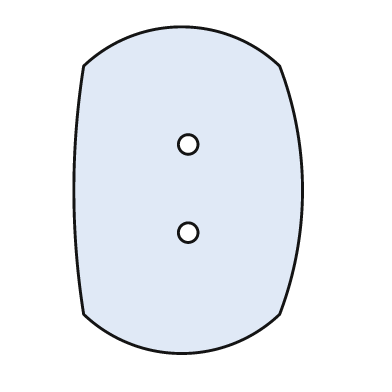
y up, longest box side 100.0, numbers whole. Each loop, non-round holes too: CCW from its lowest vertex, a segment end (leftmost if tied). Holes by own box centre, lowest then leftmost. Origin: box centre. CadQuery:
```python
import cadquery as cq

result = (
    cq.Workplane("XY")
    .moveTo(-32.0, -38.0)
    .threePointArc((-2.0, -50.0), (28.0, -38.0))
    .threePointArc((35.0, 0.0), (28.0, 38.0))
    .threePointArc((-2.0, 50.0), (-32.0, 38.0))
    .threePointArc((-35.0, 0.0), (-32.0, -38.0))
    .close()
    .moveTo(0.0, -13.0)
    .circle(3.0)
    .moveTo(0.0, 14.0)
    .circle(3.0)
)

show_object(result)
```